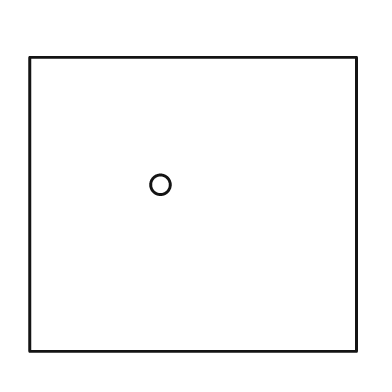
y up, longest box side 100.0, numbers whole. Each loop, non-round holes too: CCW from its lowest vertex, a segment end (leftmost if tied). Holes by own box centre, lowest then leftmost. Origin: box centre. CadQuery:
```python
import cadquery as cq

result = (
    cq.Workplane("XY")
    .moveTo(-50.0, -45.0)
    .lineTo(50.0, -45.0)
    .lineTo(50.0, 45.0)
    .lineTo(-50.0, 45.0)
    .close()
    .moveTo(-10.0, 6.0)
    .circle(3.0)
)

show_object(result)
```